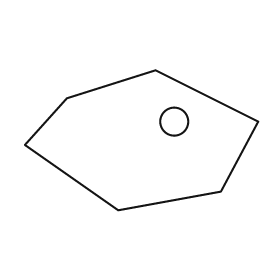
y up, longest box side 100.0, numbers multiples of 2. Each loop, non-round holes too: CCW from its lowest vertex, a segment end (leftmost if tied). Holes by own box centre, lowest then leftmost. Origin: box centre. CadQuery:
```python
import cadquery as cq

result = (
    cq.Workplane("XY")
    .moveTo(-10.0, -30.0)
    .lineTo(34.0, -22.0)
    .lineTo(50.0, 8.0)
    .lineTo(6.0, 30.0)
    .lineTo(-32.0, 18.0)
    .lineTo(-50.0, -2.0)
    .close()
    .moveTo(14.0, 8.0)
    .circle(6.0)
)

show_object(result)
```